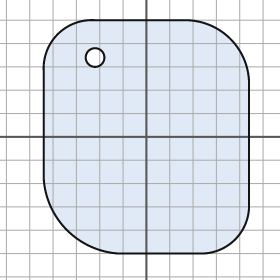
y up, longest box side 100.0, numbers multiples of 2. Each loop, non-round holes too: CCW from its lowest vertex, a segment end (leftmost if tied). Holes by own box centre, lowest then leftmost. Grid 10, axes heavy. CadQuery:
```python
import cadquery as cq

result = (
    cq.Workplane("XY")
    .moveTo(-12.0, -50.0)
    .lineTo(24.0, -50.0)
    .threePointArc((38.0, -44.0), (44.0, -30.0))
    .lineTo(44.0, 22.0)
    .threePointArc((36.0, 42.0), (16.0, 50.0))
    .lineTo(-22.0, 50.0)
    .threePointArc((-38.0, 44.0), (-44.0, 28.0))
    .lineTo(-44.0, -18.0)
    .threePointArc((-34.0, -40.0), (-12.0, -50.0))
    .close()
    .moveTo(-22.0, 34.0)
    .circle(4.0)
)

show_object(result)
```